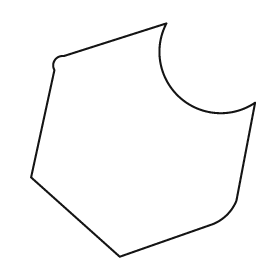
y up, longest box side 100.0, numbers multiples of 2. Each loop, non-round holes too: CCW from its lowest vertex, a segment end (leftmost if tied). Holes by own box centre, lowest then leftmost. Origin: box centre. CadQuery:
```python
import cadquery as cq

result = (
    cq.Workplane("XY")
    .moveTo(-10.0, -50.0)
    .lineTo(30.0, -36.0)
    .threePointArc((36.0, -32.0), (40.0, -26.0))
    .lineTo(48.0, 16.0)
    .threePointArc((16.0, 18.0), (10.0, 50.0))
    .lineTo(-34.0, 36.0)
    .threePointArc((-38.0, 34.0), (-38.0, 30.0))
    .lineTo(-48.0, -16.0)
    .close()
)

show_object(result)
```